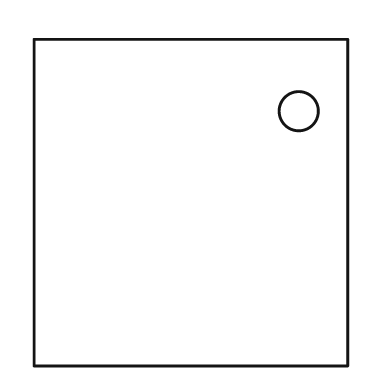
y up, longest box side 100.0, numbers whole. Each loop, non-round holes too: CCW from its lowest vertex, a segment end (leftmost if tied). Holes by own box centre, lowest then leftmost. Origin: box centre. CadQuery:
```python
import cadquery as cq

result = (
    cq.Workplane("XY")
    .moveTo(-48.0, -50.0)
    .lineTo(48.0, -50.0)
    .lineTo(48.0, 50.0)
    .lineTo(-48.0, 50.0)
    .close()
    .moveTo(33.0, 28.0)
    .circle(6.0)
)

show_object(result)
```